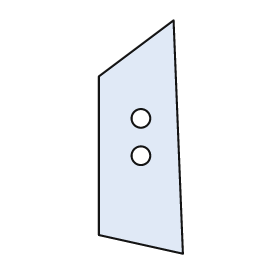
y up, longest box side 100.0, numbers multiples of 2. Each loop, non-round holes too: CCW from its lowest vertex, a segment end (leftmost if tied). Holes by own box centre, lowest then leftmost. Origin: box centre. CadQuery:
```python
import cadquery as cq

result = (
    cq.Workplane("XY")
    .moveTo(18.0, -50.0)
    .lineTo(14.0, 50.0)
    .lineTo(-18.0, 26.0)
    .lineTo(-18.0, -42.0)
    .close()
    .moveTo(0.0, -8.0)
    .circle(4.0)
    .moveTo(0.0, 8.0)
    .circle(4.0)
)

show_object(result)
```